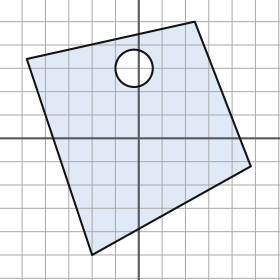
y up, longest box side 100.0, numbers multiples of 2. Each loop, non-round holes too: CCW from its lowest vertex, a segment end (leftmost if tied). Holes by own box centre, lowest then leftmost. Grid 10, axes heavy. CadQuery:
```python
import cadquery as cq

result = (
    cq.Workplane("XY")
    .moveTo(-20.0, -50.0)
    .lineTo(48.0, -12.0)
    .lineTo(24.0, 50.0)
    .lineTo(-48.0, 34.0)
    .close()
    .moveTo(-2.0, 30.0)
    .circle(8.0)
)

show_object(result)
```